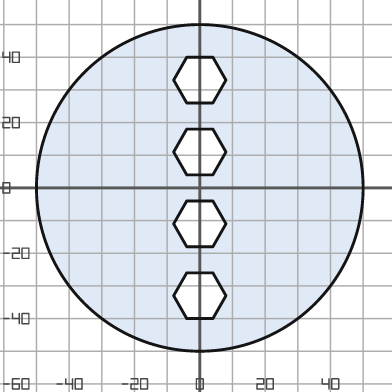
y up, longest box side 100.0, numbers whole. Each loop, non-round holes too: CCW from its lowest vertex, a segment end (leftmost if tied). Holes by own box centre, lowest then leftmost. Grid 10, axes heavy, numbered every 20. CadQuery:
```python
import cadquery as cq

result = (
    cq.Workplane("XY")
    .moveTo(0.0, 0.0)
    .circle(50.0)
    .moveTo(-4.0, -40.0)
    .lineTo(4.0, -40.0)
    .lineTo(8.0, -33.0)
    .lineTo(4.0, -26.0)
    .lineTo(-4.0, -26.0)
    .lineTo(-8.0, -33.0)
    .close()
    .moveTo(-4.0, -18.0)
    .lineTo(4.0, -18.0)
    .lineTo(8.0, -11.0)
    .lineTo(4.0, -4.0)
    .lineTo(-4.0, -4.0)
    .lineTo(-8.0, -11.0)
    .close()
    .moveTo(-4.0, 4.0)
    .lineTo(4.0, 4.0)
    .lineTo(8.0, 11.0)
    .lineTo(4.0, 18.0)
    .lineTo(-4.0, 18.0)
    .lineTo(-8.0, 11.0)
    .close()
    .moveTo(-4.0, 26.0)
    .lineTo(4.0, 26.0)
    .lineTo(8.0, 33.0)
    .lineTo(4.0, 40.0)
    .lineTo(-4.0, 40.0)
    .lineTo(-8.0, 33.0)
    .close()
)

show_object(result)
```